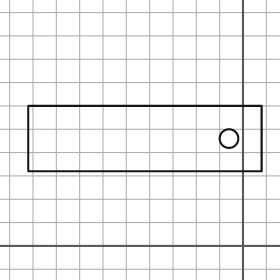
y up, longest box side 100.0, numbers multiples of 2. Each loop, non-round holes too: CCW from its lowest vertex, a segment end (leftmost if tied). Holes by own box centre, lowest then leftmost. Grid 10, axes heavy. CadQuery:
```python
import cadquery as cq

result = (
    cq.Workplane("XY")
    .moveTo(-92.0, 32.0)
    .lineTo(8.0, 32.0)
    .lineTo(8.0, 60.0)
    .lineTo(-92.0, 60.0)
    .close()
    .moveTo(-6.0, 46.0)
    .circle(4.0)
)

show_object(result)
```